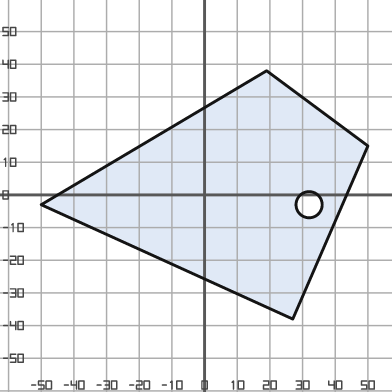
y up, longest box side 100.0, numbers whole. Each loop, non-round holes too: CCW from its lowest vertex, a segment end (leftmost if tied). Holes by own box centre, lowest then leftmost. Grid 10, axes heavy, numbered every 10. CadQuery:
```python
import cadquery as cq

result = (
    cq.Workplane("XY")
    .moveTo(27.0, -38.0)
    .lineTo(50.0, 15.0)
    .lineTo(19.0, 38.0)
    .lineTo(-50.0, -3.0)
    .close()
    .moveTo(32.0, -3.0)
    .circle(4.0)
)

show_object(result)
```